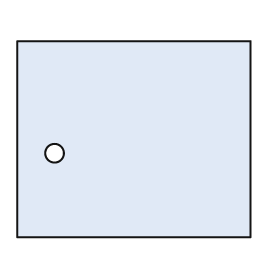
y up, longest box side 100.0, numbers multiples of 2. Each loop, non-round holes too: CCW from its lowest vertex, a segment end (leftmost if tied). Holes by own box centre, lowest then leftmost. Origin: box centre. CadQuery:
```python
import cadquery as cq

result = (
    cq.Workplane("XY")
    .moveTo(-50.0, -42.0)
    .lineTo(50.0, -42.0)
    .lineTo(50.0, 42.0)
    .lineTo(-50.0, 42.0)
    .close()
    .moveTo(-34.0, -6.0)
    .circle(4.0)
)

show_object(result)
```